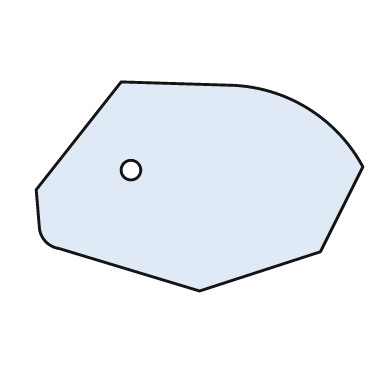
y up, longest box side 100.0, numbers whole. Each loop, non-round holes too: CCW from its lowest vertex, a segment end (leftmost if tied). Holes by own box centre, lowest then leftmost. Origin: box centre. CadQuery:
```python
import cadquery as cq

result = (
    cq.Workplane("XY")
    .moveTo(0.0, -32.0)
    .lineTo(37.0, -20.0)
    .lineTo(50.0, 6.0)
    .threePointArc((33.0, 24.0), (9.0, 31.0))
    .lineTo(-24.0, 32.0)
    .lineTo(-50.0, -1.0)
    .lineTo(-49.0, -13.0)
    .threePointArc((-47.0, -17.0), (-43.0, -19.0))
    .close()
    .moveTo(-21.0, 5.0)
    .circle(3.0)
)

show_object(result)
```